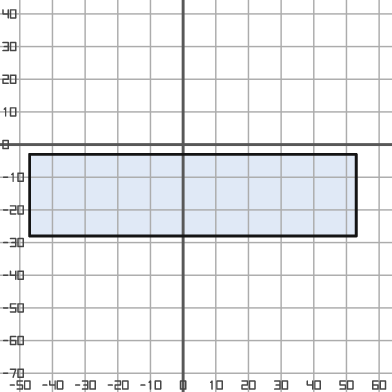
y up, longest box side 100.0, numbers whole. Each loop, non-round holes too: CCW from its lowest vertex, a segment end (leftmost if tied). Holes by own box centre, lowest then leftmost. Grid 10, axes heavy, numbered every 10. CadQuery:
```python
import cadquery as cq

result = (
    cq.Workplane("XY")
    .moveTo(-47.0, -28.0)
    .lineTo(53.0, -28.0)
    .lineTo(53.0, -3.0)
    .lineTo(-47.0, -3.0)
    .close()
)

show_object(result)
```